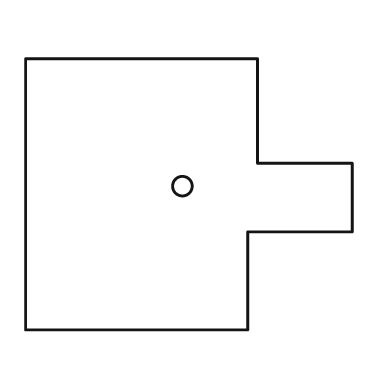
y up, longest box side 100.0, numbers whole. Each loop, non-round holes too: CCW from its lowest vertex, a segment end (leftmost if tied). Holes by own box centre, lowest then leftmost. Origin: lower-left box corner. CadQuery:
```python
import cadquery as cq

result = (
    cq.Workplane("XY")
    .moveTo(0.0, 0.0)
    .lineTo(68.0, 0.0)
    .lineTo(68.0, 30.0)
    .lineTo(100.0, 30.0)
    .lineTo(100.0, 51.0)
    .lineTo(71.0, 51.0)
    .lineTo(71.0, 83.0)
    .lineTo(0.0, 83.0)
    .close()
    .moveTo(48.0, 44.0)
    .circle(3.0)
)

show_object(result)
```